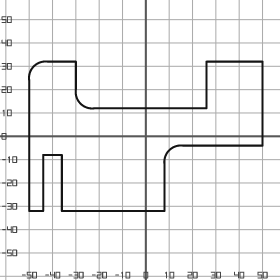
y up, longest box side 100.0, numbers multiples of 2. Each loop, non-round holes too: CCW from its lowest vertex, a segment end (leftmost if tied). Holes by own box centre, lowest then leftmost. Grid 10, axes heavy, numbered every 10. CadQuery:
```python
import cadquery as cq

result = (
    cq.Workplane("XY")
    .moveTo(-50.0, -32.0)
    .lineTo(-44.0, -32.0)
    .lineTo(-44.0, -8.0)
    .lineTo(-36.0, -8.0)
    .lineTo(-36.0, -32.0)
    .lineTo(8.0, -32.0)
    .lineTo(8.0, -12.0)
    .threePointArc((10.0, -6.0), (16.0, -4.0))
    .lineTo(50.0, -4.0)
    .lineTo(50.0, 32.0)
    .lineTo(26.0, 32.0)
    .lineTo(26.0, 12.0)
    .lineTo(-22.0, 12.0)
    .threePointArc((-28.0, 14.0), (-30.0, 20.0))
    .lineTo(-30.0, 32.0)
    .lineTo(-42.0, 32.0)
    .threePointArc((-48.0, 30.0), (-50.0, 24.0))
    .close()
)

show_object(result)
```